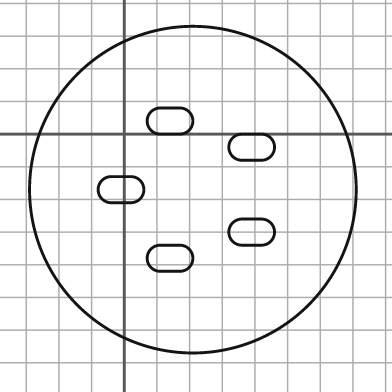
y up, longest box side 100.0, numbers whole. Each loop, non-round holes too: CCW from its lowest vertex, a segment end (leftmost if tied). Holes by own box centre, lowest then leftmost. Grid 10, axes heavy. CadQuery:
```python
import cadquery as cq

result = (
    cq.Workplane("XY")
    .moveTo(21.0, -17.0)
    .circle(50.0)
    .moveTo(11.0, -42.0)
    .lineTo(17.0, -42.0)
    .threePointArc((21.0, -38.0), (17.0, -34.0))
    .lineTo(11.0, -34.0)
    .threePointArc((7.0, -38.0), (11.0, -42.0))
    .close()
    .moveTo(36.0, -34.0)
    .lineTo(42.0, -34.0)
    .threePointArc((46.0, -30.0), (42.0, -26.0))
    .lineTo(36.0, -26.0)
    .threePointArc((32.0, -30.0), (36.0, -34.0))
    .close()
    .moveTo(-4.0, -21.0)
    .lineTo(2.0, -21.0)
    .threePointArc((6.0, -17.0), (2.0, -13.0))
    .lineTo(-4.0, -13.0)
    .threePointArc((-8.0, -17.0), (-4.0, -21.0))
    .close()
    .moveTo(36.0, -8.0)
    .lineTo(42.0, -8.0)
    .threePointArc((46.0, -4.0), (42.0, 0.0))
    .lineTo(36.0, 0.0)
    .threePointArc((32.0, -4.0), (36.0, -8.0))
    .close()
    .moveTo(11.0, 0.0)
    .lineTo(17.0, 0.0)
    .threePointArc((21.0, 4.0), (17.0, 8.0))
    .lineTo(11.0, 8.0)
    .threePointArc((7.0, 4.0), (11.0, 0.0))
    .close()
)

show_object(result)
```